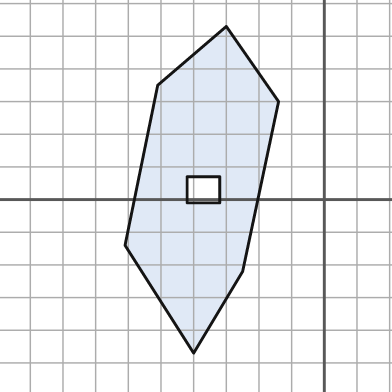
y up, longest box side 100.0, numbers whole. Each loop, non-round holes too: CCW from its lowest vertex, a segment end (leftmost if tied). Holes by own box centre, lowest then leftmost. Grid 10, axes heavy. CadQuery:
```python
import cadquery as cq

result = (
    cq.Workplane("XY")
    .moveTo(-40.0, -47.0)
    .lineTo(-25.0, -22.0)
    .lineTo(-14.0, 30.0)
    .lineTo(-30.0, 53.0)
    .lineTo(-51.0, 35.0)
    .lineTo(-61.0, -14.0)
    .close()
    .moveTo(-42.0, -1.0)
    .lineTo(-32.0, -1.0)
    .lineTo(-32.0, 7.0)
    .lineTo(-42.0, 7.0)
    .close()
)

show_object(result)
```